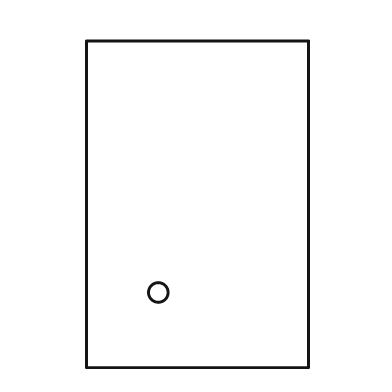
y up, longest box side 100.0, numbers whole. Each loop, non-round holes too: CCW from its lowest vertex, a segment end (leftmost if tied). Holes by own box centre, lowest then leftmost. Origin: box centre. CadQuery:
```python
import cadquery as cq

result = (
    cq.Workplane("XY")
    .moveTo(-34.0, -50.0)
    .lineTo(34.0, -50.0)
    .lineTo(34.0, 50.0)
    .lineTo(-34.0, 50.0)
    .close()
    .moveTo(-12.0, -27.0)
    .circle(3.0)
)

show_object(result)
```